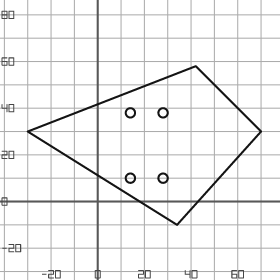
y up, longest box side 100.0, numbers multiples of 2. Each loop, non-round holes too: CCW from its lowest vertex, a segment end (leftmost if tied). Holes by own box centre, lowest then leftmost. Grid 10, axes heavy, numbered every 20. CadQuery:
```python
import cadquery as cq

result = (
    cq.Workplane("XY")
    .moveTo(34.0, -10.0)
    .lineTo(70.0, 30.0)
    .lineTo(42.0, 58.0)
    .lineTo(-30.0, 30.0)
    .close()
    .moveTo(14.0, 10.0)
    .circle(2.0)
    .moveTo(28.0, 10.0)
    .circle(2.0)
    .moveTo(14.0, 38.0)
    .circle(2.0)
    .moveTo(28.0, 38.0)
    .circle(2.0)
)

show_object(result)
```